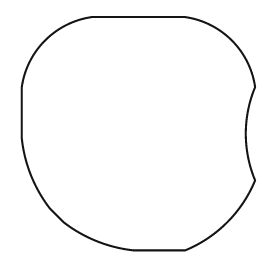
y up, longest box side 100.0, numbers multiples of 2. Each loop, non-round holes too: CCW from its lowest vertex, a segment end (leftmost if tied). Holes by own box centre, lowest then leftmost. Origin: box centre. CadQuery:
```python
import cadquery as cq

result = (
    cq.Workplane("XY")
    .moveTo(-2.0, -50.0)
    .lineTo(20.0, -50.0)
    .threePointArc((38.0, -38.0), (50.0, -20.0))
    .threePointArc((46.0, 0.0), (50.0, 20.0))
    .threePointArc((40.0, 40.0), (20.0, 50.0))
    .lineTo(-20.0, 50.0)
    .threePointArc((-40.0, 40.0), (-50.0, 20.0))
    .lineTo(-50.0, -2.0)
    .threePointArc((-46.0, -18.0), (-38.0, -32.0))
    .lineTo(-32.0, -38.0)
    .threePointArc((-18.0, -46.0), (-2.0, -50.0))
    .close()
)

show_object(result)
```